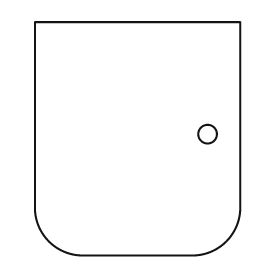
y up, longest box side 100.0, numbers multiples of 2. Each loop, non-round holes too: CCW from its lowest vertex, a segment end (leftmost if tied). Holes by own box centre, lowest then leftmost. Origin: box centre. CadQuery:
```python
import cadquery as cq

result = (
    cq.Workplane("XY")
    .moveTo(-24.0, -50.0)
    .lineTo(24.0, -50.0)
    .threePointArc((38.0, -44.0), (44.0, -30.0))
    .lineTo(44.0, 50.0)
    .lineTo(-44.0, 50.0)
    .lineTo(-44.0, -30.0)
    .threePointArc((-38.0, -44.0), (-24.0, -50.0))
    .close()
    .moveTo(30.0, 2.0)
    .circle(4.0)
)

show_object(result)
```